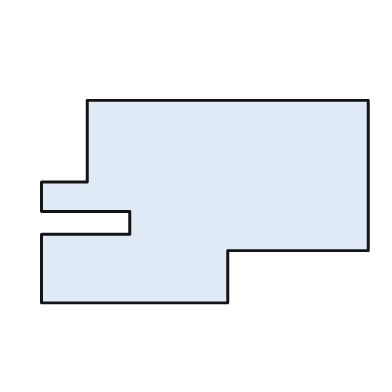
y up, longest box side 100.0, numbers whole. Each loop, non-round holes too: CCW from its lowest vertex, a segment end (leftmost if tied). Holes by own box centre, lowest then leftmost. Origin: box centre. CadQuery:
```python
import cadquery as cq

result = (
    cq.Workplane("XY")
    .moveTo(-50.0, -31.0)
    .lineTo(7.0, -31.0)
    .lineTo(7.0, -15.0)
    .lineTo(50.0, -15.0)
    .lineTo(50.0, 31.0)
    .lineTo(-36.0, 31.0)
    .lineTo(-36.0, 6.0)
    .lineTo(-50.0, 6.0)
    .lineTo(-50.0, -3.0)
    .lineTo(-23.0, -3.0)
    .lineTo(-23.0, -10.0)
    .lineTo(-50.0, -10.0)
    .close()
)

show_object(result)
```